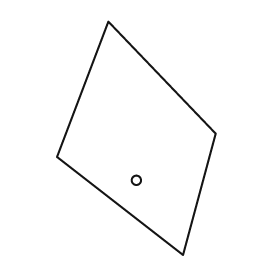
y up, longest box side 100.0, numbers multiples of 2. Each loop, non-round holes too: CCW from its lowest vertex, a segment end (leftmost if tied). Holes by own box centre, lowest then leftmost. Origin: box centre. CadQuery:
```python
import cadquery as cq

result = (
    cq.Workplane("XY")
    .moveTo(20.0, -50.0)
    .lineTo(34.0, 2.0)
    .lineTo(-12.0, 50.0)
    .lineTo(-34.0, -8.0)
    .close()
    .moveTo(0.0, -18.0)
    .circle(2.0)
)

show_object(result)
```